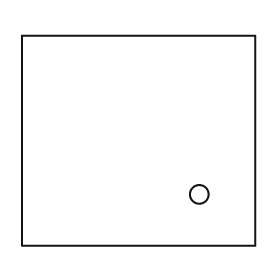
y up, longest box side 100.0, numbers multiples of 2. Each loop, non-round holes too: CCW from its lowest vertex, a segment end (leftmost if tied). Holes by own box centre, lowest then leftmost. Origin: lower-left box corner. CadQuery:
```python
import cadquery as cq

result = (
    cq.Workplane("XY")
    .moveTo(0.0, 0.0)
    .lineTo(100.0, 0.0)
    .lineTo(100.0, 90.0)
    .lineTo(0.0, 90.0)
    .close()
    .moveTo(76.0, 22.0)
    .circle(4.0)
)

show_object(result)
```